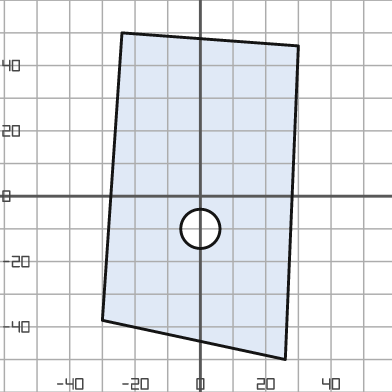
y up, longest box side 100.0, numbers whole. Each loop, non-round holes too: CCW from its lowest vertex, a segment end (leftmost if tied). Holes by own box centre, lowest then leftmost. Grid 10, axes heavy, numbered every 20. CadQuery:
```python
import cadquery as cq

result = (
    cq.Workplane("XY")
    .moveTo(26.0, -50.0)
    .lineTo(30.0, 46.0)
    .lineTo(-24.0, 50.0)
    .lineTo(-30.0, -38.0)
    .close()
    .moveTo(0.0, -10.0)
    .circle(6.0)
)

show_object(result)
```